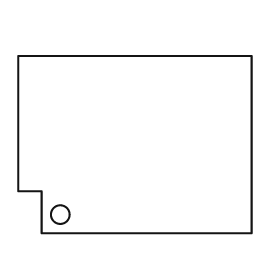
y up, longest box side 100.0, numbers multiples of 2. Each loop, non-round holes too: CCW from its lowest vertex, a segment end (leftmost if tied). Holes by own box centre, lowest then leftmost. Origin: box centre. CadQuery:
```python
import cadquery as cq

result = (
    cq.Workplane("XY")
    .moveTo(-40.0, -38.0)
    .lineTo(50.0, -38.0)
    .lineTo(50.0, 38.0)
    .lineTo(-50.0, 38.0)
    .lineTo(-50.0, -20.0)
    .lineTo(-40.0, -20.0)
    .close()
    .moveTo(-32.0, -30.0)
    .circle(4.0)
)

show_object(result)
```